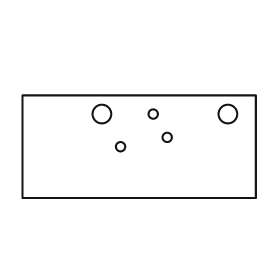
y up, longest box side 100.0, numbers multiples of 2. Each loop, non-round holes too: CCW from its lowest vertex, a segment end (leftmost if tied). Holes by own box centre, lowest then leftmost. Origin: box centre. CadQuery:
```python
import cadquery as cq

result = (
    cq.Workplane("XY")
    .moveTo(-50.0, -22.0)
    .lineTo(50.0, -22.0)
    .lineTo(50.0, 22.0)
    .lineTo(-50.0, 22.0)
    .close()
    .moveTo(-8.0, 0.0)
    .circle(2.0)
    .moveTo(12.0, 4.0)
    .circle(2.0)
    .moveTo(-16.0, 14.0)
    .circle(4.0)
    .moveTo(6.0, 14.0)
    .circle(2.0)
    .moveTo(38.0, 14.0)
    .circle(4.0)
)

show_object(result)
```